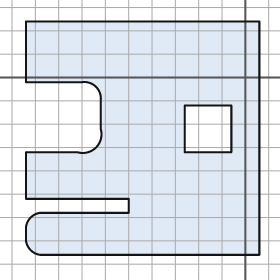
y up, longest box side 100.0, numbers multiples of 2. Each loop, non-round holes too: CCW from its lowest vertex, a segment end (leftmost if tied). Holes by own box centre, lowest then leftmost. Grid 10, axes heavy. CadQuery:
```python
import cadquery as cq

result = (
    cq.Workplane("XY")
    .moveTo(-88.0, -76.0)
    .lineTo(6.0, -76.0)
    .lineTo(6.0, 24.0)
    .lineTo(-94.0, 24.0)
    .lineTo(-94.0, -2.0)
    .lineTo(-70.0, -2.0)
    .threePointArc((-64.0, -4.0), (-62.0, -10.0))
    .lineTo(-62.0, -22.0)
    .threePointArc((-64.0, -30.0), (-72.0, -32.0))
    .lineTo(-94.0, -32.0)
    .lineTo(-94.0, -52.0)
    .lineTo(-50.0, -52.0)
    .lineTo(-50.0, -58.0)
    .lineTo(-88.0, -58.0)
    .threePointArc((-92.0, -60.0), (-94.0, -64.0))
    .lineTo(-94.0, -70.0)
    .threePointArc((-92.0, -74.0), (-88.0, -76.0))
    .close()
    .moveTo(-26.0, -32.0)
    .lineTo(-6.0, -32.0)
    .lineTo(-6.0, -12.0)
    .lineTo(-26.0, -12.0)
    .close()
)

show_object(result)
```